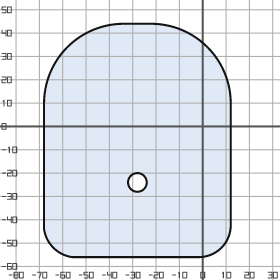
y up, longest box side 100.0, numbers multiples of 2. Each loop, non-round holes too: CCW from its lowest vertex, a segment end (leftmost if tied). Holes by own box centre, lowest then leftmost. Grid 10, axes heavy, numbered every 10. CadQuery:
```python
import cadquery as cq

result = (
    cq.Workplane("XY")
    .moveTo(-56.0, -56.0)
    .lineTo(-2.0, -56.0)
    .threePointArc((8.0, -52.0), (12.0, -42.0))
    .lineTo(12.0, 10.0)
    .threePointArc((2.0, 34.0), (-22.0, 44.0))
    .lineTo(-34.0, 44.0)
    .threePointArc((-58.0, 34.0), (-68.0, 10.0))
    .lineTo(-68.0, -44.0)
    .threePointArc((-64.0, -52.0), (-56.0, -56.0))
    .close()
    .moveTo(-28.0, -24.0)
    .circle(4.0)
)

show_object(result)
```